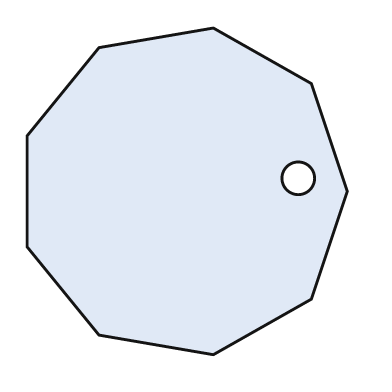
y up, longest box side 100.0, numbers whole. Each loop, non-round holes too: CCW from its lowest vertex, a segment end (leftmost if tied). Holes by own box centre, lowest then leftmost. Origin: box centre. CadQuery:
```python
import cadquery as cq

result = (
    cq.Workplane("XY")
    .moveTo(8.0, -50.0)
    .lineTo(38.0, -33.0)
    .lineTo(49.0, 0.0)
    .lineTo(38.0, 33.0)
    .lineTo(8.0, 50.0)
    .lineTo(-27.0, 44.0)
    .lineTo(-49.0, 17.0)
    .lineTo(-49.0, -17.0)
    .lineTo(-27.0, -44.0)
    .close()
    .moveTo(34.0, 4.0)
    .circle(5.0)
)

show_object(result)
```